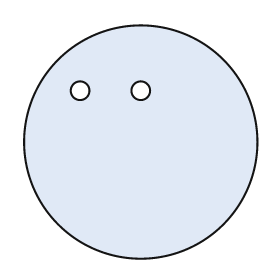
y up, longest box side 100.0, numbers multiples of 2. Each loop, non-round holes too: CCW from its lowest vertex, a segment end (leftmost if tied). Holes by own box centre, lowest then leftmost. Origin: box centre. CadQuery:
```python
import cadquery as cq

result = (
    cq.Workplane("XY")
    .moveTo(0.0, 0.0)
    .circle(50.0)
    .moveTo(-26.0, 22.0)
    .circle(4.0)
    .moveTo(0.0, 22.0)
    .circle(4.0)
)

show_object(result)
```